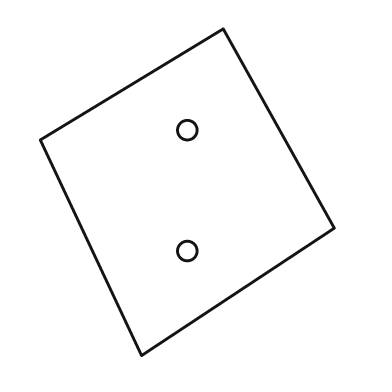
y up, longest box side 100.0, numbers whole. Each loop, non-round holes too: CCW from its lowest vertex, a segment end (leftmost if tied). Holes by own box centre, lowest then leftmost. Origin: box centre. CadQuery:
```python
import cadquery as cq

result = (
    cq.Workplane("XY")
    .moveTo(-14.0, -50.0)
    .lineTo(45.0, -11.0)
    .lineTo(11.0, 50.0)
    .lineTo(-45.0, 16.0)
    .close()
    .moveTo(0.0, -18.0)
    .circle(3.0)
    .moveTo(0.0, 19.0)
    .circle(3.0)
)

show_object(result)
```